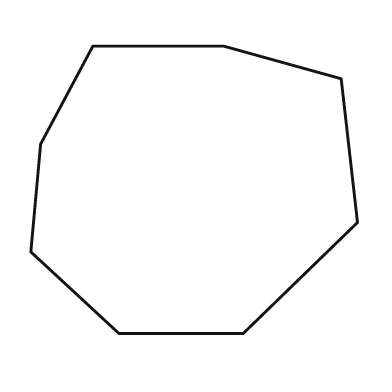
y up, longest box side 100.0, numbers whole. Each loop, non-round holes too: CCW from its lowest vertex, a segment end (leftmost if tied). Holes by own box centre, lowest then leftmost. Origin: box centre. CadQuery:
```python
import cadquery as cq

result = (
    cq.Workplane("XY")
    .moveTo(-23.0, -44.0)
    .lineTo(15.0, -44.0)
    .lineTo(50.0, -10.0)
    .lineTo(45.0, 34.0)
    .lineTo(9.0, 44.0)
    .lineTo(-31.0, 44.0)
    .lineTo(-47.0, 14.0)
    .lineTo(-50.0, -19.0)
    .close()
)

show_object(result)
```